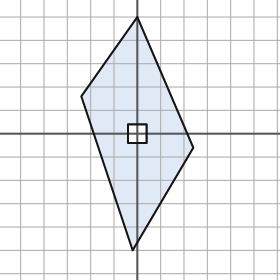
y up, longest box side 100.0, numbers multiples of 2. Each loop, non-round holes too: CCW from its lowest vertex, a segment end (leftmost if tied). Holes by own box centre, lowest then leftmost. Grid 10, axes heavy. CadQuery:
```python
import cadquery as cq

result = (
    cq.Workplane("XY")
    .moveTo(-2.0, -50.0)
    .lineTo(24.0, -6.0)
    .lineTo(0.0, 50.0)
    .lineTo(-24.0, 16.0)
    .close()
    .moveTo(-4.0, -4.0)
    .lineTo(4.0, -4.0)
    .lineTo(4.0, 4.0)
    .lineTo(-4.0, 4.0)
    .close()
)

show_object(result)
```